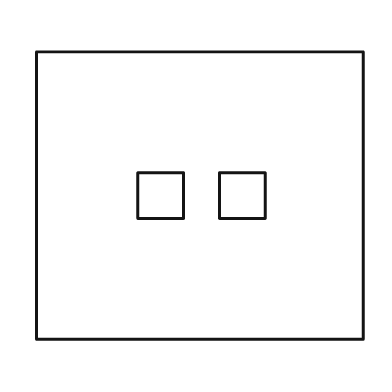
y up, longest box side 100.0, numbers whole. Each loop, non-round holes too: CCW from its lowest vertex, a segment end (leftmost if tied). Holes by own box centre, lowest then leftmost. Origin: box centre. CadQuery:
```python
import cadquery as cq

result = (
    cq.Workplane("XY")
    .moveTo(-50.0, -44.0)
    .lineTo(50.0, -44.0)
    .lineTo(50.0, 44.0)
    .lineTo(-50.0, 44.0)
    .close()
    .moveTo(-19.0, -7.0)
    .lineTo(-5.0, -7.0)
    .lineTo(-5.0, 7.0)
    .lineTo(-19.0, 7.0)
    .close()
    .moveTo(6.0, -7.0)
    .lineTo(20.0, -7.0)
    .lineTo(20.0, 7.0)
    .lineTo(6.0, 7.0)
    .close()
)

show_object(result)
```